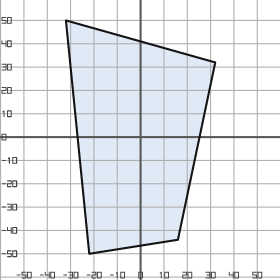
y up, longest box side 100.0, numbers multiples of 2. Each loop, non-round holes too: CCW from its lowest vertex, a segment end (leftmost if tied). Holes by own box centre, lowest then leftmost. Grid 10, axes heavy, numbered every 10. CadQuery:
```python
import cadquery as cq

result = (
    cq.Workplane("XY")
    .moveTo(-22.0, -50.0)
    .lineTo(16.0, -44.0)
    .lineTo(32.0, 32.0)
    .lineTo(-32.0, 50.0)
    .close()
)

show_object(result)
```